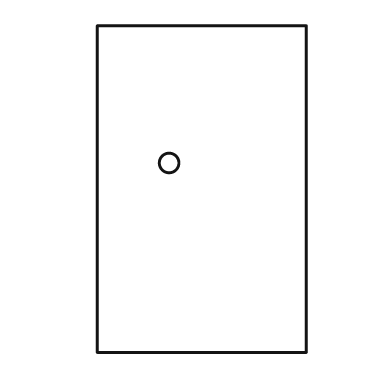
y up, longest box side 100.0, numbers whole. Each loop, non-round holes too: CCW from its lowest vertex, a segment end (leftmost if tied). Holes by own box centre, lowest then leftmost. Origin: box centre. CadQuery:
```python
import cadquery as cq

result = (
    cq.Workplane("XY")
    .moveTo(-32.0, -50.0)
    .lineTo(32.0, -50.0)
    .lineTo(32.0, 50.0)
    .lineTo(-32.0, 50.0)
    .close()
    .moveTo(-10.0, 8.0)
    .circle(3.0)
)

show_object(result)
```